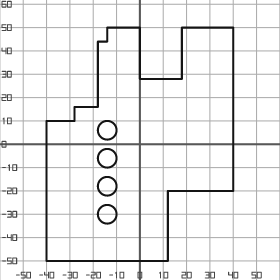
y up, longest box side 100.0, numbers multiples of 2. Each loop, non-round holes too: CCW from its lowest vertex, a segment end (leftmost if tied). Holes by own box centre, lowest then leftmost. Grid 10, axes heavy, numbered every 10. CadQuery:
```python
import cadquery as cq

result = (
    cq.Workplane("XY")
    .moveTo(-40.0, -50.0)
    .lineTo(12.0, -50.0)
    .lineTo(12.0, -20.0)
    .lineTo(40.0, -20.0)
    .lineTo(40.0, 50.0)
    .lineTo(18.0, 50.0)
    .lineTo(18.0, 28.0)
    .lineTo(0.0, 28.0)
    .lineTo(0.0, 50.0)
    .lineTo(-14.0, 50.0)
    .lineTo(-14.0, 44.0)
    .lineTo(-18.0, 44.0)
    .lineTo(-18.0, 16.0)
    .lineTo(-28.0, 16.0)
    .lineTo(-28.0, 10.0)
    .lineTo(-40.0, 10.0)
    .close()
    .moveTo(-14.0, -30.0)
    .circle(4.0)
    .moveTo(-14.0, -18.0)
    .circle(4.0)
    .moveTo(-14.0, -6.0)
    .circle(4.0)
    .moveTo(-14.0, 6.0)
    .circle(4.0)
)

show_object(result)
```